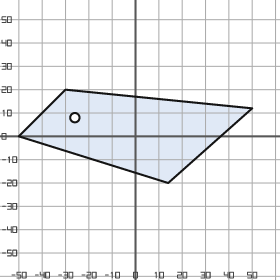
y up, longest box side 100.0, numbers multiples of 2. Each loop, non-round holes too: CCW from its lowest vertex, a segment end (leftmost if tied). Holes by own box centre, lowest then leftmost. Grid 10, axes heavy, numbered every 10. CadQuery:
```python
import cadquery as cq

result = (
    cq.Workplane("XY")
    .moveTo(14.0, -20.0)
    .lineTo(50.0, 12.0)
    .lineTo(-30.0, 20.0)
    .lineTo(-50.0, 0.0)
    .close()
    .moveTo(-26.0, 8.0)
    .circle(2.0)
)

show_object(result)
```